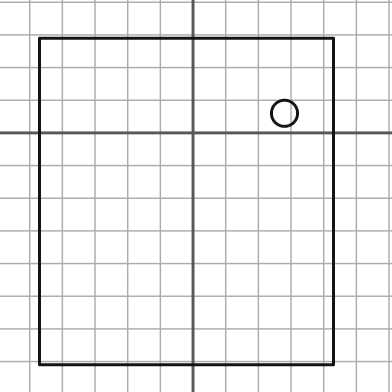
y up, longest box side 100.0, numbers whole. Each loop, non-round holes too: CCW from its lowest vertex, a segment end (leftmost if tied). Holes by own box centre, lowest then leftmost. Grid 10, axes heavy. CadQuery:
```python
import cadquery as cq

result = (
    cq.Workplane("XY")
    .moveTo(-47.0, -71.0)
    .lineTo(43.0, -71.0)
    .lineTo(43.0, 29.0)
    .lineTo(-47.0, 29.0)
    .close()
    .moveTo(28.0, 6.0)
    .circle(4.0)
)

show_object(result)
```